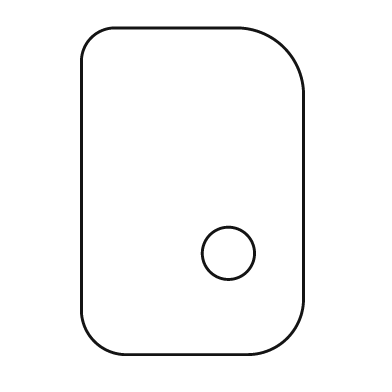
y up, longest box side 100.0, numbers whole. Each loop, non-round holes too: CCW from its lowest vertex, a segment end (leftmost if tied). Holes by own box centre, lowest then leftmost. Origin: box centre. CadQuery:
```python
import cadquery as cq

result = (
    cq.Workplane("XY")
    .moveTo(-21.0, -50.0)
    .lineTo(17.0, -50.0)
    .threePointArc((29.0, -45.0), (34.0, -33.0))
    .lineTo(34.0, 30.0)
    .threePointArc((28.0, 44.0), (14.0, 50.0))
    .lineTo(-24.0, 50.0)
    .threePointArc((-31.0, 47.0), (-34.0, 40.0))
    .lineTo(-34.0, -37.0)
    .threePointArc((-30.0, -46.0), (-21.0, -50.0))
    .close()
    .moveTo(11.0, -19.0)
    .circle(8.0)
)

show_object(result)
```